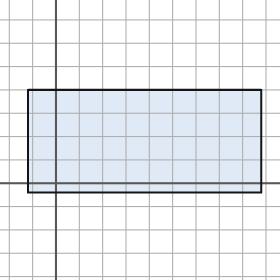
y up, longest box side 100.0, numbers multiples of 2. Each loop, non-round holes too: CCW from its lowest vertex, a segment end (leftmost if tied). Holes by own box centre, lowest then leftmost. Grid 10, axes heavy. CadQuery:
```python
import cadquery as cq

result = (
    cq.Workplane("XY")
    .moveTo(-12.0, -4.0)
    .lineTo(88.0, -4.0)
    .lineTo(88.0, 40.0)
    .lineTo(-12.0, 40.0)
    .close()
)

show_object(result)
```